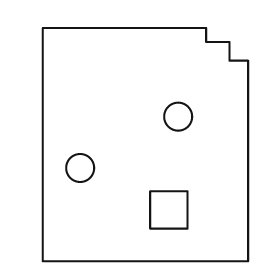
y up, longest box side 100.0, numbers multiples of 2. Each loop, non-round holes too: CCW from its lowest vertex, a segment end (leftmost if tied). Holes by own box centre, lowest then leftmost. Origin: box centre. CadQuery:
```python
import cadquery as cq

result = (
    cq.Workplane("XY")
    .moveTo(-44.0, -50.0)
    .lineTo(44.0, -50.0)
    .lineTo(44.0, 36.0)
    .lineTo(36.0, 36.0)
    .lineTo(36.0, 44.0)
    .lineTo(26.0, 44.0)
    .lineTo(26.0, 50.0)
    .lineTo(-44.0, 50.0)
    .close()
    .moveTo(2.0, -36.0)
    .lineTo(18.0, -36.0)
    .lineTo(18.0, -20.0)
    .lineTo(2.0, -20.0)
    .close()
    .moveTo(-28.0, -10.0)
    .circle(6.0)
    .moveTo(14.0, 12.0)
    .circle(6.0)
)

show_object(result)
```